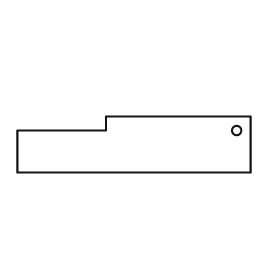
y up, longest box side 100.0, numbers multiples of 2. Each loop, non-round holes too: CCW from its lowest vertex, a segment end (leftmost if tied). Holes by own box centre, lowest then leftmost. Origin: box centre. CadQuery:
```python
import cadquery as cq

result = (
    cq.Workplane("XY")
    .moveTo(-50.0, -12.0)
    .lineTo(50.0, -12.0)
    .lineTo(50.0, 12.0)
    .lineTo(-12.0, 12.0)
    .lineTo(-12.0, 6.0)
    .lineTo(-50.0, 6.0)
    .close()
    .moveTo(44.0, 6.0)
    .circle(2.0)
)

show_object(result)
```